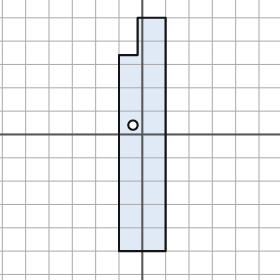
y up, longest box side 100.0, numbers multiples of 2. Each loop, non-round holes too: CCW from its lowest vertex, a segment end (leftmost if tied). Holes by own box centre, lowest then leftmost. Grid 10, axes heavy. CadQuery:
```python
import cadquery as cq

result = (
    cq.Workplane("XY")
    .moveTo(-10.0, -50.0)
    .lineTo(10.0, -50.0)
    .lineTo(10.0, 50.0)
    .lineTo(-2.0, 50.0)
    .lineTo(-2.0, 34.0)
    .lineTo(-10.0, 34.0)
    .close()
    .moveTo(-4.0, 4.0)
    .circle(2.0)
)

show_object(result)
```